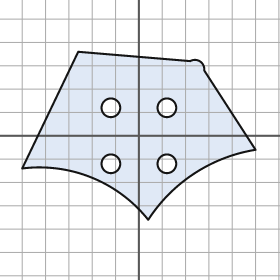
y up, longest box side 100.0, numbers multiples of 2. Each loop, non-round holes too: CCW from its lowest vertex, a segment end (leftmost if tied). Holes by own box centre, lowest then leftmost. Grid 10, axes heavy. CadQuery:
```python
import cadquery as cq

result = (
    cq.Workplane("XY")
    .moveTo(4.0, -36.0)
    .threePointArc((24.0, -16.0), (50.0, -6.0))
    .lineTo(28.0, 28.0)
    .threePointArc((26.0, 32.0), (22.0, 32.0))
    .lineTo(-26.0, 36.0)
    .lineTo(-50.0, -14.0)
    .threePointArc((-20.0, -18.0), (4.0, -36.0))
    .close()
    .moveTo(-12.0, -12.0)
    .circle(4.0)
    .moveTo(12.0, -12.0)
    .circle(4.0)
    .moveTo(-12.0, 12.0)
    .circle(4.0)
    .moveTo(12.0, 12.0)
    .circle(4.0)
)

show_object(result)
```